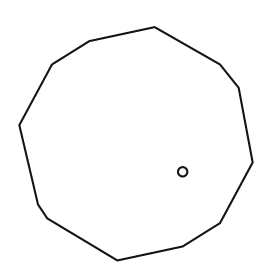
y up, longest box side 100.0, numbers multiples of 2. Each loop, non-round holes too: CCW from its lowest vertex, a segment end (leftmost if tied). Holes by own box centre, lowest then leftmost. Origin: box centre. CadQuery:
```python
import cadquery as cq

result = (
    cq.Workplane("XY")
    .moveTo(-8.0, -50.0)
    .lineTo(20.0, -44.0)
    .lineTo(36.0, -34.0)
    .lineTo(50.0, -8.0)
    .lineTo(44.0, 24.0)
    .lineTo(36.0, 34.0)
    .lineTo(8.0, 50.0)
    .lineTo(-20.0, 44.0)
    .lineTo(-36.0, 34.0)
    .lineTo(-50.0, 8.0)
    .lineTo(-42.0, -26.0)
    .lineTo(-38.0, -32.0)
    .close()
    .moveTo(20.0, -12.0)
    .circle(2.0)
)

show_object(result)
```